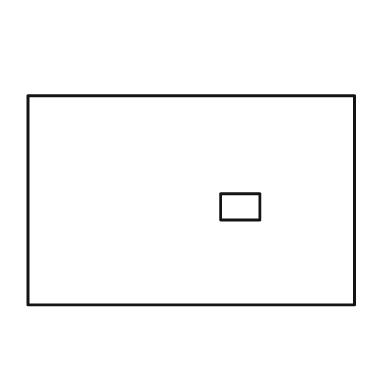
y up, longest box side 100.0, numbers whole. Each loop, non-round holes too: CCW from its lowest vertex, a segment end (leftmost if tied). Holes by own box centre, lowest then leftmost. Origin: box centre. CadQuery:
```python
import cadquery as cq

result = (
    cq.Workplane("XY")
    .moveTo(-50.0, -32.0)
    .lineTo(50.0, -32.0)
    .lineTo(50.0, 32.0)
    .lineTo(-50.0, 32.0)
    .close()
    .moveTo(9.0, -6.0)
    .lineTo(21.0, -6.0)
    .lineTo(21.0, 2.0)
    .lineTo(9.0, 2.0)
    .close()
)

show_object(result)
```